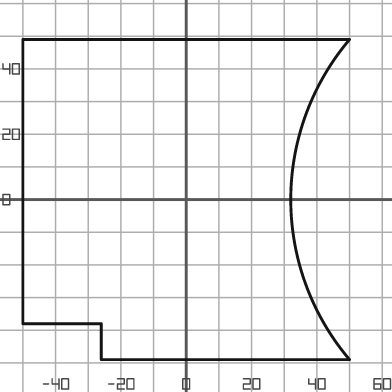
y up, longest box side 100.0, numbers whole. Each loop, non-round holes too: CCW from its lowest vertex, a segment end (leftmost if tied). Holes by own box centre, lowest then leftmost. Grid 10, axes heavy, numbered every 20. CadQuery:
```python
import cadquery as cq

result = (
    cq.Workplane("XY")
    .moveTo(-26.0, -49.0)
    .lineTo(50.0, -49.0)
    .threePointArc((32.0, 0.0), (50.0, 49.0))
    .lineTo(-50.0, 49.0)
    .lineTo(-50.0, -38.0)
    .lineTo(-26.0, -38.0)
    .close()
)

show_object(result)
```